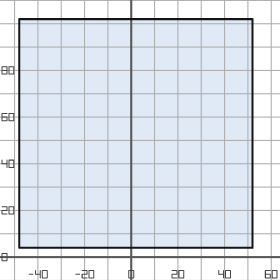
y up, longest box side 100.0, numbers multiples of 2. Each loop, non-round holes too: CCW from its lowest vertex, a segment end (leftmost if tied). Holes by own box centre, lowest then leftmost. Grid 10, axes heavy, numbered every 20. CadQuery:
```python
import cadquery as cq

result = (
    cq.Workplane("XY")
    .moveTo(-48.0, 4.0)
    .lineTo(52.0, 4.0)
    .lineTo(52.0, 102.0)
    .lineTo(-48.0, 102.0)
    .close()
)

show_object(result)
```